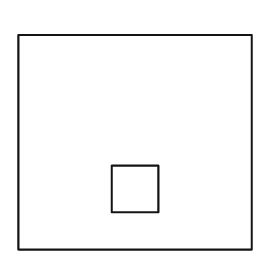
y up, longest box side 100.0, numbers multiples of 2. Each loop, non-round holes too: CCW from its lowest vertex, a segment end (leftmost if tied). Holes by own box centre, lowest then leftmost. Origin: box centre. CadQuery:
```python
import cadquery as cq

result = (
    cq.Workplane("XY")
    .moveTo(-50.0, -46.0)
    .lineTo(50.0, -46.0)
    .lineTo(50.0, 46.0)
    .lineTo(-50.0, 46.0)
    .close()
    .moveTo(-10.0, -30.0)
    .lineTo(10.0, -30.0)
    .lineTo(10.0, -10.0)
    .lineTo(-10.0, -10.0)
    .close()
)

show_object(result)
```